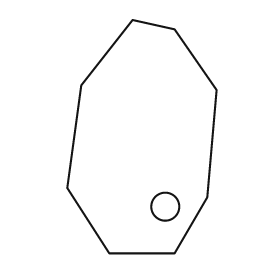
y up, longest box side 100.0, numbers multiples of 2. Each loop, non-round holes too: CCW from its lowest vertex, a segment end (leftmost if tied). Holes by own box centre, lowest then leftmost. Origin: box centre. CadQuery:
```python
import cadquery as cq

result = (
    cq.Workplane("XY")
    .moveTo(-14.0, -50.0)
    .lineTo(14.0, -50.0)
    .lineTo(28.0, -26.0)
    .lineTo(32.0, 20.0)
    .lineTo(14.0, 46.0)
    .lineTo(-4.0, 50.0)
    .lineTo(-26.0, 22.0)
    .lineTo(-32.0, -22.0)
    .close()
    .moveTo(10.0, -30.0)
    .circle(6.0)
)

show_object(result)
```